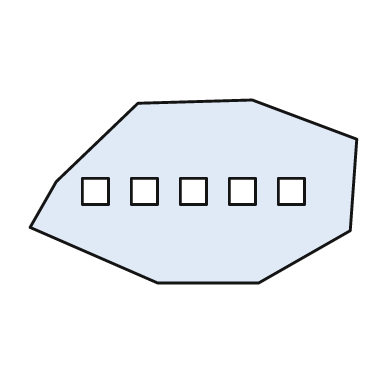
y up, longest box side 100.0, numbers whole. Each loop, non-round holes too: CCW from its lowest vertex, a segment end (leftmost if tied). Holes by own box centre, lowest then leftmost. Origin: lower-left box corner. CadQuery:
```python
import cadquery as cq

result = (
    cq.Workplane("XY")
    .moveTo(39.0, 0.0)
    .lineTo(70.0, 0.0)
    .lineTo(98.0, 16.0)
    .lineTo(100.0, 44.0)
    .lineTo(68.0, 56.0)
    .lineTo(33.0, 55.0)
    .lineTo(8.0, 31.0)
    .lineTo(0.0, 17.0)
    .close()
    .moveTo(16.0, 24.0)
    .lineTo(24.0, 24.0)
    .lineTo(24.0, 32.0)
    .lineTo(16.0, 32.0)
    .close()
    .moveTo(31.0, 24.0)
    .lineTo(39.0, 24.0)
    .lineTo(39.0, 32.0)
    .lineTo(31.0, 32.0)
    .close()
    .moveTo(46.0, 24.0)
    .lineTo(54.0, 24.0)
    .lineTo(54.0, 32.0)
    .lineTo(46.0, 32.0)
    .close()
    .moveTo(61.0, 24.0)
    .lineTo(69.0, 24.0)
    .lineTo(69.0, 32.0)
    .lineTo(61.0, 32.0)
    .close()
    .moveTo(76.0, 24.0)
    .lineTo(84.0, 24.0)
    .lineTo(84.0, 32.0)
    .lineTo(76.0, 32.0)
    .close()
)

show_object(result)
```